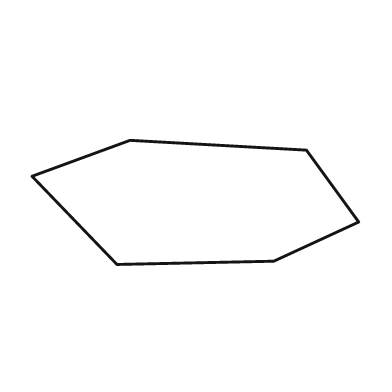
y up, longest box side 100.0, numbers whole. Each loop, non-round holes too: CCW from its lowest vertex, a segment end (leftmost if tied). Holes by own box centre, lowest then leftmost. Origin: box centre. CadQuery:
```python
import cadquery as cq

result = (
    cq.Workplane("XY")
    .moveTo(-24.0, -19.0)
    .lineTo(24.0, -18.0)
    .lineTo(50.0, -6.0)
    .lineTo(34.0, 16.0)
    .lineTo(-20.0, 19.0)
    .lineTo(-50.0, 8.0)
    .close()
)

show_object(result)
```